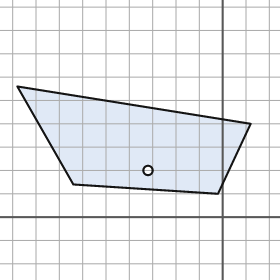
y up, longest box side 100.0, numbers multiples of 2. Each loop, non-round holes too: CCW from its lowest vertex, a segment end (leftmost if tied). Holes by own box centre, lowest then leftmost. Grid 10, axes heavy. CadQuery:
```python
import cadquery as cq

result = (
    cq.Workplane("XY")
    .moveTo(-2.0, 10.0)
    .lineTo(12.0, 40.0)
    .lineTo(-88.0, 56.0)
    .lineTo(-64.0, 14.0)
    .close()
    .moveTo(-32.0, 20.0)
    .circle(2.0)
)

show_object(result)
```